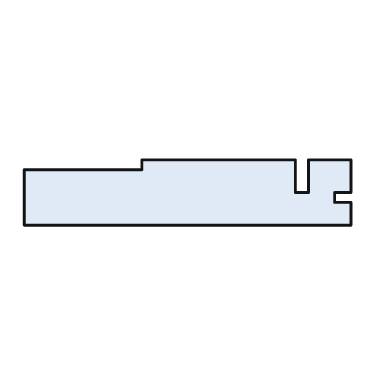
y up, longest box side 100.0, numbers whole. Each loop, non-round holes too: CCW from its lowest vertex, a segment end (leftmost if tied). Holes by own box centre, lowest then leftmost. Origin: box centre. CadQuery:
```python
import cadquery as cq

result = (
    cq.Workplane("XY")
    .moveTo(-50.0, -10.0)
    .lineTo(50.0, -10.0)
    .lineTo(50.0, -3.0)
    .lineTo(45.0, -3.0)
    .lineTo(45.0, 0.0)
    .lineTo(50.0, 0.0)
    .lineTo(50.0, 10.0)
    .lineTo(37.0, 10.0)
    .lineTo(37.0, 0.0)
    .lineTo(33.0, 0.0)
    .lineTo(33.0, 10.0)
    .lineTo(-14.0, 10.0)
    .lineTo(-14.0, 7.0)
    .lineTo(-50.0, 7.0)
    .close()
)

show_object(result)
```